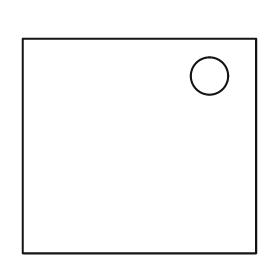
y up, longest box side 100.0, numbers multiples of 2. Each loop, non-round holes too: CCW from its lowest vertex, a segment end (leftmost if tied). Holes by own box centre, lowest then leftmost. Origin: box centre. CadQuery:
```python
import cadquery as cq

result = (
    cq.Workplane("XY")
    .moveTo(-50.0, -46.0)
    .lineTo(50.0, -46.0)
    .lineTo(50.0, 46.0)
    .lineTo(-50.0, 46.0)
    .close()
    .moveTo(30.0, 30.0)
    .circle(8.0)
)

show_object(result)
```